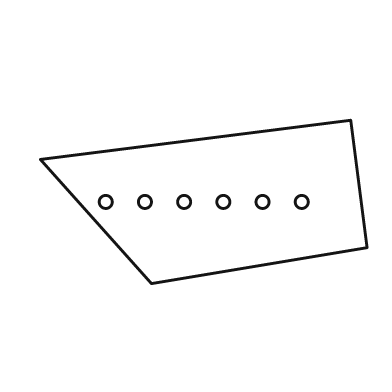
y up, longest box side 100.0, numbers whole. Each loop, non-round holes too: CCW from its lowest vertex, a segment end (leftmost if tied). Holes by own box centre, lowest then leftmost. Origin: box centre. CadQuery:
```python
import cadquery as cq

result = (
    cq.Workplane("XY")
    .moveTo(-16.0, -25.0)
    .lineTo(50.0, -14.0)
    .lineTo(45.0, 25.0)
    .lineTo(-50.0, 13.0)
    .close()
    .moveTo(-30.0, 0.0)
    .circle(2.0)
    .moveTo(-18.0, 0.0)
    .circle(2.0)
    .moveTo(-6.0, 0.0)
    .circle(2.0)
    .moveTo(6.0, 0.0)
    .circle(2.0)
    .moveTo(18.0, 0.0)
    .circle(2.0)
    .moveTo(30.0, 0.0)
    .circle(2.0)
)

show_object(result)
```